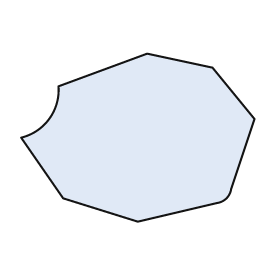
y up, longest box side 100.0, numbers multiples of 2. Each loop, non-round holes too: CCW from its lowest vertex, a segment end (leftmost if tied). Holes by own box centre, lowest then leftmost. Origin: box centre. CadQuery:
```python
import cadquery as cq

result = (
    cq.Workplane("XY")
    .moveTo(0.0, -36.0)
    .lineTo(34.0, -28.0)
    .threePointArc((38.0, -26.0), (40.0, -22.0))
    .lineTo(50.0, 8.0)
    .lineTo(32.0, 30.0)
    .lineTo(4.0, 36.0)
    .lineTo(-34.0, 22.0)
    .threePointArc((-38.0, 8.0), (-50.0, 0.0))
    .lineTo(-32.0, -26.0)
    .close()
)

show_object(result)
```